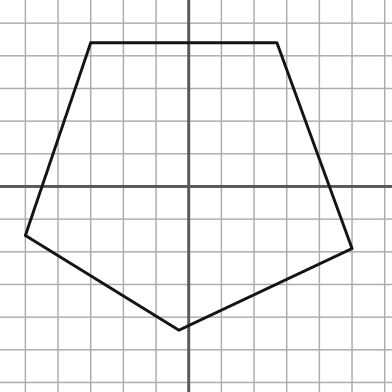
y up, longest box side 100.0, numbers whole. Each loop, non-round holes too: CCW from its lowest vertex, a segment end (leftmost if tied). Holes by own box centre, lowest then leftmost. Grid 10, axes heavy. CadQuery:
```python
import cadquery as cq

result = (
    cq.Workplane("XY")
    .moveTo(-3.0, -44.0)
    .lineTo(50.0, -19.0)
    .lineTo(27.0, 44.0)
    .lineTo(-30.0, 44.0)
    .lineTo(-50.0, -15.0)
    .close()
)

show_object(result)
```